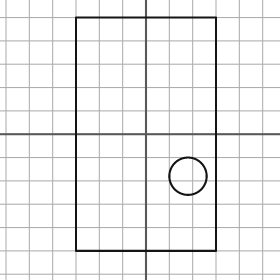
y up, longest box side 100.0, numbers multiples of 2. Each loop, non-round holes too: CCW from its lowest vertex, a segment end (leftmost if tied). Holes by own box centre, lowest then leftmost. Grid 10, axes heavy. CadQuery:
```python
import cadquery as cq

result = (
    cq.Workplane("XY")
    .moveTo(-30.0, -50.0)
    .lineTo(30.0, -50.0)
    .lineTo(30.0, 50.0)
    .lineTo(-30.0, 50.0)
    .close()
    .moveTo(18.0, -18.0)
    .circle(8.0)
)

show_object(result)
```